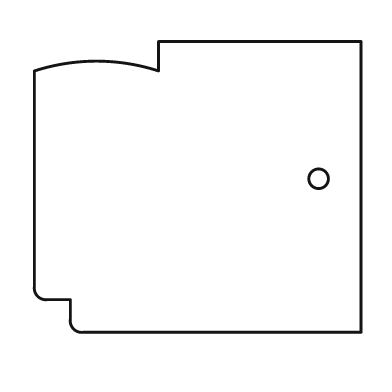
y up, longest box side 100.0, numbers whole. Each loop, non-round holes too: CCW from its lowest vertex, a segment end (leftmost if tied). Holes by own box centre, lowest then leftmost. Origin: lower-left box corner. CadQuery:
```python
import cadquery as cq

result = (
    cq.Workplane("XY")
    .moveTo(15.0, 0.0)
    .lineTo(100.0, 0.0)
    .lineTo(100.0, 89.0)
    .lineTo(38.0, 89.0)
    .lineTo(38.0, 80.0)
    .threePointArc((19.0, 83.0), (0.0, 80.0))
    .lineTo(0.0, 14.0)
    .threePointArc((1.0, 11.0), (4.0, 10.0))
    .lineTo(11.0, 10.0)
    .lineTo(11.0, 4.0)
    .threePointArc((12.0, 1.0), (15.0, 0.0))
    .close()
    .moveTo(87.0, 47.0)
    .circle(3.0)
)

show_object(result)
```